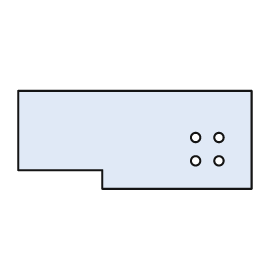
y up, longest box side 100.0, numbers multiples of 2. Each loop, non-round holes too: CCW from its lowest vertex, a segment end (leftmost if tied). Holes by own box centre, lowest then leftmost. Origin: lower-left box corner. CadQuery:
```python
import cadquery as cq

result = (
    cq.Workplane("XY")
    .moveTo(36.0, 0.0)
    .lineTo(100.0, 0.0)
    .lineTo(100.0, 42.0)
    .lineTo(0.0, 42.0)
    .lineTo(0.0, 8.0)
    .lineTo(36.0, 8.0)
    .close()
    .moveTo(76.0, 12.0)
    .circle(2.0)
    .moveTo(86.0, 12.0)
    .circle(2.0)
    .moveTo(76.0, 22.0)
    .circle(2.0)
    .moveTo(86.0, 22.0)
    .circle(2.0)
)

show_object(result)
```